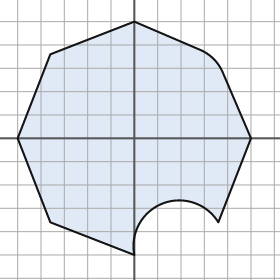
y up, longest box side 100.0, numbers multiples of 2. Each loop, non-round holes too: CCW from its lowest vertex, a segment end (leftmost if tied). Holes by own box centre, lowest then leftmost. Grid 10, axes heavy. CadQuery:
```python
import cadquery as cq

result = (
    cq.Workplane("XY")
    .moveTo(0.0, -50.0)
    .threePointArc((12.0, -28.0), (36.0, -36.0))
    .lineTo(50.0, 0.0)
    .lineTo(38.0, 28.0)
    .threePointArc((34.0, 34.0), (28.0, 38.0))
    .lineTo(0.0, 50.0)
    .lineTo(-36.0, 36.0)
    .lineTo(-50.0, 0.0)
    .lineTo(-36.0, -36.0)
    .close()
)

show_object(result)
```